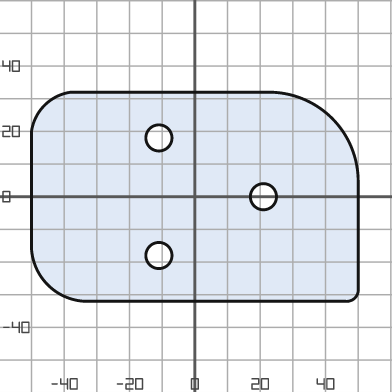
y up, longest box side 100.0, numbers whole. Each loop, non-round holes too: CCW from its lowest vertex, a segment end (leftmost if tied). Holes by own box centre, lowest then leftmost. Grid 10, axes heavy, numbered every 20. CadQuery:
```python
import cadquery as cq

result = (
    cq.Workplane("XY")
    .moveTo(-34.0, -32.0)
    .lineTo(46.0, -32.0)
    .threePointArc((49.0, -31.0), (50.0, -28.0))
    .lineTo(50.0, 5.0)
    .threePointArc((42.0, 24.0), (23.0, 32.0))
    .lineTo(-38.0, 32.0)
    .threePointArc((-46.0, 28.0), (-50.0, 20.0))
    .lineTo(-50.0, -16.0)
    .threePointArc((-45.0, -27.0), (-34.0, -32.0))
    .close()
    .moveTo(-11.0, -18.0)
    .circle(4.0)
    .moveTo(21.0, 0.0)
    .circle(4.0)
    .moveTo(-11.0, 18.0)
    .circle(4.0)
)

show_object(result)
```